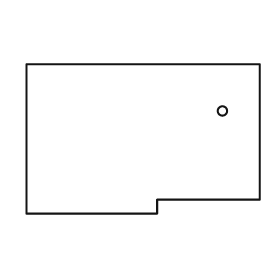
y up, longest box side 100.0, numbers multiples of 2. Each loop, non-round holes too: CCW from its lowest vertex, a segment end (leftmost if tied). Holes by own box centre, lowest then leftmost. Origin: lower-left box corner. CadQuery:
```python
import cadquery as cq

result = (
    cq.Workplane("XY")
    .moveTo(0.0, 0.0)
    .lineTo(56.0, 0.0)
    .lineTo(56.0, 6.0)
    .lineTo(100.0, 6.0)
    .lineTo(100.0, 64.0)
    .lineTo(0.0, 64.0)
    .close()
    .moveTo(84.0, 44.0)
    .circle(2.0)
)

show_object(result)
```